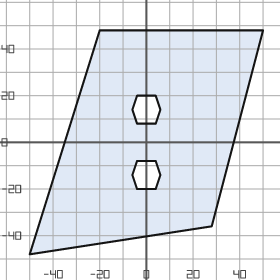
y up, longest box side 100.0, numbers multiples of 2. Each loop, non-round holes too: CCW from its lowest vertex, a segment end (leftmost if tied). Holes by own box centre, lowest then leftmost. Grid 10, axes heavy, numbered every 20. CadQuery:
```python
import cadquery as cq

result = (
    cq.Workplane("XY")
    .moveTo(-50.0, -48.0)
    .lineTo(28.0, -36.0)
    .lineTo(50.0, 48.0)
    .lineTo(-20.0, 48.0)
    .close()
    .moveTo(-4.0, -20.0)
    .lineTo(4.0, -20.0)
    .lineTo(6.0, -14.0)
    .lineTo(4.0, -8.0)
    .lineTo(-4.0, -8.0)
    .lineTo(-6.0, -14.0)
    .close()
    .moveTo(-4.0, 8.0)
    .lineTo(4.0, 8.0)
    .lineTo(6.0, 14.0)
    .lineTo(4.0, 20.0)
    .lineTo(-4.0, 20.0)
    .lineTo(-6.0, 14.0)
    .close()
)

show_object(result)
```